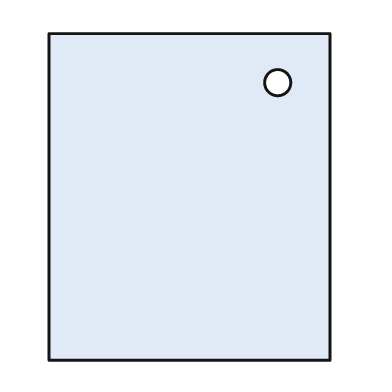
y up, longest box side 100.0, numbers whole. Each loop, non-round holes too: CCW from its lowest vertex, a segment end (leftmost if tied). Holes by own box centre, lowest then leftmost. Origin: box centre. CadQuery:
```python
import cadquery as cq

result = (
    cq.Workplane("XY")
    .moveTo(-43.0, -50.0)
    .lineTo(43.0, -50.0)
    .lineTo(43.0, 50.0)
    .lineTo(-43.0, 50.0)
    .close()
    .moveTo(27.0, 35.0)
    .circle(4.0)
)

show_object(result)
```